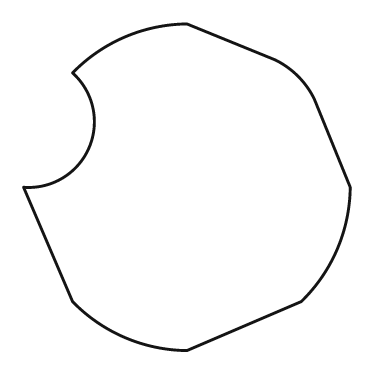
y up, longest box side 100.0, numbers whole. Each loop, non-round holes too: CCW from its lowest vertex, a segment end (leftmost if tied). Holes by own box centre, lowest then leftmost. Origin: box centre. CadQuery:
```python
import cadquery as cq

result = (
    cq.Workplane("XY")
    .moveTo(0.0, -50.0)
    .lineTo(35.0, -35.0)
    .threePointArc((46.0, -19.0), (50.0, 0.0))
    .lineTo(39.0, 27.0)
    .threePointArc((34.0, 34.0), (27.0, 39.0))
    .lineTo(0.0, 50.0)
    .threePointArc((-19.0, 46.0), (-35.0, 35.0))
    .threePointArc((-30.0, 12.0), (-50.0, 0.0))
    .lineTo(-35.0, -35.0)
    .threePointArc((-19.0, -46.0), (0.0, -50.0))
    .close()
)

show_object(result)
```